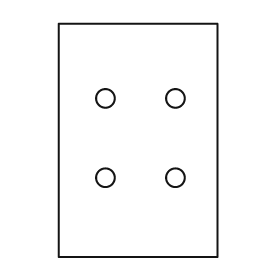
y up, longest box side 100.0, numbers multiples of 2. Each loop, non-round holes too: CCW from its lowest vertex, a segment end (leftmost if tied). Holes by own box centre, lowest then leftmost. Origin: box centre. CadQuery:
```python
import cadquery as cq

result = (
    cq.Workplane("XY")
    .moveTo(-34.0, -50.0)
    .lineTo(34.0, -50.0)
    .lineTo(34.0, 50.0)
    .lineTo(-34.0, 50.0)
    .close()
    .moveTo(-14.0, -16.0)
    .circle(4.0)
    .moveTo(16.0, -16.0)
    .circle(4.0)
    .moveTo(-14.0, 18.0)
    .circle(4.0)
    .moveTo(16.0, 18.0)
    .circle(4.0)
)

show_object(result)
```